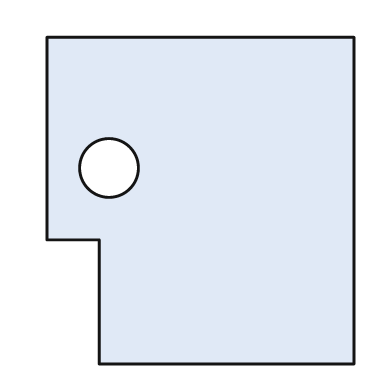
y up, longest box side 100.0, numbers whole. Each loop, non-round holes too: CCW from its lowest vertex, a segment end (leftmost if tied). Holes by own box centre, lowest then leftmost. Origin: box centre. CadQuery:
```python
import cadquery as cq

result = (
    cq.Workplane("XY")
    .moveTo(-31.0, -50.0)
    .lineTo(47.0, -50.0)
    .lineTo(47.0, 50.0)
    .lineTo(-47.0, 50.0)
    .lineTo(-47.0, -12.0)
    .lineTo(-31.0, -12.0)
    .close()
    .moveTo(-28.0, 10.0)
    .circle(9.0)
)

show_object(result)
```